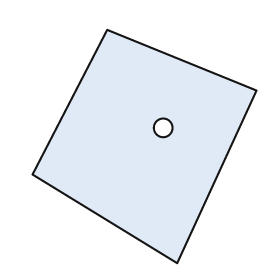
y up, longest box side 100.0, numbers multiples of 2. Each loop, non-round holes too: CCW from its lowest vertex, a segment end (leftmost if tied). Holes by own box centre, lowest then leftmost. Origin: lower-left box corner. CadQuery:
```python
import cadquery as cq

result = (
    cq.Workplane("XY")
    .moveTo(62.0, 0.0)
    .lineTo(96.0, 74.0)
    .lineTo(32.0, 100.0)
    .lineTo(0.0, 38.0)
    .close()
    .moveTo(56.0, 58.0)
    .circle(4.0)
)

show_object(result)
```